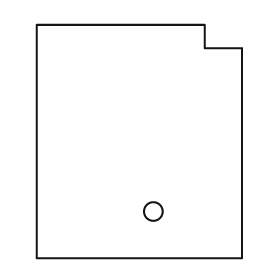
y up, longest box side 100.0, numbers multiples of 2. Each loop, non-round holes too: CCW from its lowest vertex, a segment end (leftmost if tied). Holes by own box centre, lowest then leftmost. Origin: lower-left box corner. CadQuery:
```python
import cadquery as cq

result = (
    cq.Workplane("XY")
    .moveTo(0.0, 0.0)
    .lineTo(88.0, 0.0)
    .lineTo(88.0, 90.0)
    .lineTo(72.0, 90.0)
    .lineTo(72.0, 100.0)
    .lineTo(0.0, 100.0)
    .close()
    .moveTo(50.0, 20.0)
    .circle(4.0)
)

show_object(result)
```